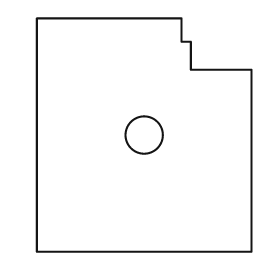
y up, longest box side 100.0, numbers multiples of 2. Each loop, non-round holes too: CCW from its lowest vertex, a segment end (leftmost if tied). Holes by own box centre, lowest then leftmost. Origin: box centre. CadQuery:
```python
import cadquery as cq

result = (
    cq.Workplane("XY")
    .moveTo(-46.0, -50.0)
    .lineTo(46.0, -50.0)
    .lineTo(46.0, 28.0)
    .lineTo(20.0, 28.0)
    .lineTo(20.0, 40.0)
    .lineTo(16.0, 40.0)
    .lineTo(16.0, 50.0)
    .lineTo(-46.0, 50.0)
    .close()
    .moveTo(0.0, 0.0)
    .circle(8.0)
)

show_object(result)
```